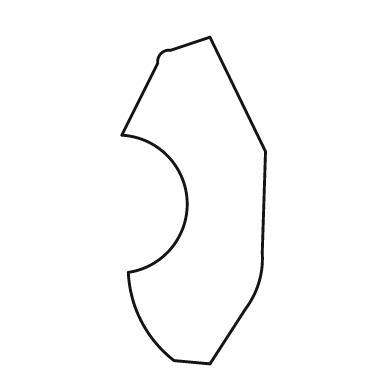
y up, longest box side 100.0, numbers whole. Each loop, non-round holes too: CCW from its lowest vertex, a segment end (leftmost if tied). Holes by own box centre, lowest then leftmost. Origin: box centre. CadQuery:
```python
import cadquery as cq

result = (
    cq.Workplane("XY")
    .moveTo(5.0, -50.0)
    .lineTo(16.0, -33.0)
    .threePointArc((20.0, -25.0), (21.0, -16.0))
    .lineTo(22.0, 15.0)
    .lineTo(5.0, 50.0)
    .lineTo(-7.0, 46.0)
    .threePointArc((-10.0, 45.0), (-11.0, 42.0))
    .lineTo(-22.0, 20.0)
    .threePointArc((-2.0, 0.0), (-20.0, -22.0))
    .threePointArc((-16.0, -37.0), (-6.0, -49.0))
    .close()
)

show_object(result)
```